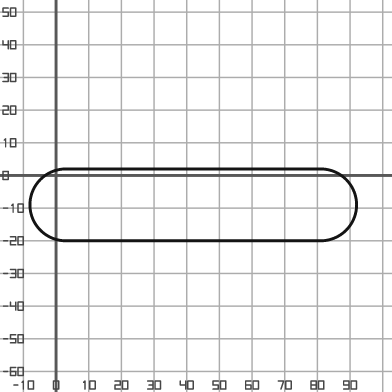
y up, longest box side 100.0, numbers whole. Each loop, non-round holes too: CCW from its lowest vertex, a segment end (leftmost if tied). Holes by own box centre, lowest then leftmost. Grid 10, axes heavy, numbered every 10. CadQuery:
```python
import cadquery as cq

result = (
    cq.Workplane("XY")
    .moveTo(3.0, -20.0)
    .lineTo(81.0, -20.0)
    .threePointArc((92.0, -9.0), (81.0, 2.0))
    .lineTo(3.0, 2.0)
    .threePointArc((-8.0, -9.0), (3.0, -20.0))
    .close()
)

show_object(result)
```